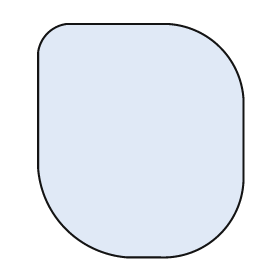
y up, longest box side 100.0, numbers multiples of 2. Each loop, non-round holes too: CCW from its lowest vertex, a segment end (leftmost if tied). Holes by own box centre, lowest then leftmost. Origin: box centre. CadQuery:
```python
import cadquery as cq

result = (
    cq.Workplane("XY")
    .moveTo(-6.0, -50.0)
    .lineTo(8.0, -50.0)
    .threePointArc((34.0, -40.0), (44.0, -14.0))
    .lineTo(44.0, 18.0)
    .threePointArc((34.0, 40.0), (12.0, 50.0))
    .lineTo(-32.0, 50.0)
    .threePointArc((-40.0, 46.0), (-44.0, 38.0))
    .lineTo(-44.0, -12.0)
    .threePointArc((-32.0, -38.0), (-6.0, -50.0))
    .close()
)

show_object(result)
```